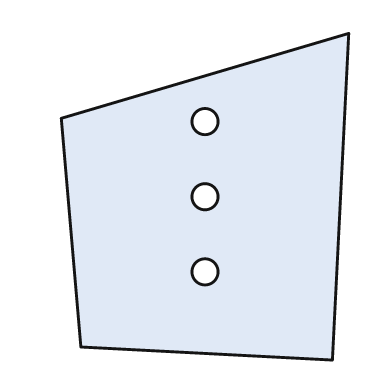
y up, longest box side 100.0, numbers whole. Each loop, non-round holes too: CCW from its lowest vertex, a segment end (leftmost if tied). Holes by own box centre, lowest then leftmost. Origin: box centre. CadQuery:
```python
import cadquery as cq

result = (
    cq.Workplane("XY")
    .moveTo(39.0, -50.0)
    .lineTo(44.0, 50.0)
    .lineTo(-44.0, 24.0)
    .lineTo(-38.0, -46.0)
    .close()
    .moveTo(0.0, -23.0)
    .circle(4.0)
    .moveTo(0.0, 0.0)
    .circle(4.0)
    .moveTo(0.0, 23.0)
    .circle(4.0)
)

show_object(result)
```